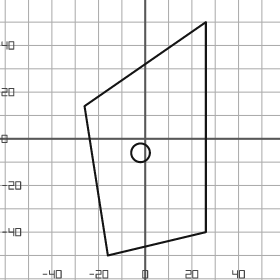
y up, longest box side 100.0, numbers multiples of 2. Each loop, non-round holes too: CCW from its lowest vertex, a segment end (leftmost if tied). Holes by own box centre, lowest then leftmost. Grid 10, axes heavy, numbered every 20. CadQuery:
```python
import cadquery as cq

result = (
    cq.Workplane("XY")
    .moveTo(-16.0, -50.0)
    .lineTo(26.0, -40.0)
    .lineTo(26.0, 50.0)
    .lineTo(-26.0, 14.0)
    .close()
    .moveTo(-2.0, -6.0)
    .circle(4.0)
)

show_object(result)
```